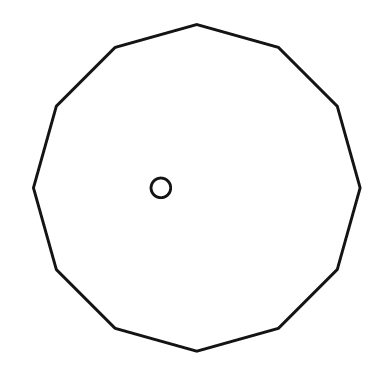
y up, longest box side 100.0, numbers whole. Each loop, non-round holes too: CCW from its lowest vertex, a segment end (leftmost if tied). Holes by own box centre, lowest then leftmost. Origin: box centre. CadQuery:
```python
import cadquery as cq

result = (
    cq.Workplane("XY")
    .moveTo(0.0, -50.0)
    .lineTo(25.0, -43.0)
    .lineTo(43.0, -25.0)
    .lineTo(50.0, 0.0)
    .lineTo(43.0, 25.0)
    .lineTo(25.0, 43.0)
    .lineTo(0.0, 50.0)
    .lineTo(-25.0, 43.0)
    .lineTo(-43.0, 25.0)
    .lineTo(-50.0, 0.0)
    .lineTo(-43.0, -25.0)
    .lineTo(-25.0, -43.0)
    .close()
    .moveTo(-11.0, 0.0)
    .circle(3.0)
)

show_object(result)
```